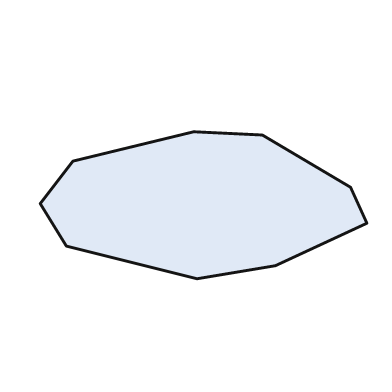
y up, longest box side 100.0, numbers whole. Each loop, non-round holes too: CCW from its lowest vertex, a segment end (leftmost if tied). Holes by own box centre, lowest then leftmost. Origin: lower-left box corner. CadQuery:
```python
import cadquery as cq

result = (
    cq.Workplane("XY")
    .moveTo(48.0, 0.0)
    .lineTo(72.0, 4.0)
    .lineTo(100.0, 17.0)
    .lineTo(95.0, 28.0)
    .lineTo(68.0, 44.0)
    .lineTo(47.0, 45.0)
    .lineTo(10.0, 36.0)
    .lineTo(0.0, 23.0)
    .lineTo(8.0, 10.0)
    .close()
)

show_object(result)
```